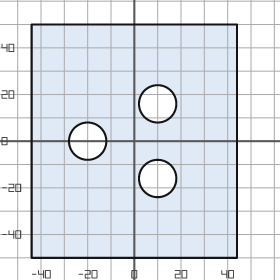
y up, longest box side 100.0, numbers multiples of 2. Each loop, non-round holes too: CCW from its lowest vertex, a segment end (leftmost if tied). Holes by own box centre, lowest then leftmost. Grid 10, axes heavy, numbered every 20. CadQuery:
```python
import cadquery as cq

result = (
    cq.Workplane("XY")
    .moveTo(-44.0, -50.0)
    .lineTo(44.0, -50.0)
    .lineTo(44.0, 50.0)
    .lineTo(-44.0, 50.0)
    .close()
    .moveTo(10.0, -16.0)
    .circle(8.0)
    .moveTo(-20.0, 0.0)
    .circle(8.0)
    .moveTo(10.0, 16.0)
    .circle(8.0)
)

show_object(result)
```